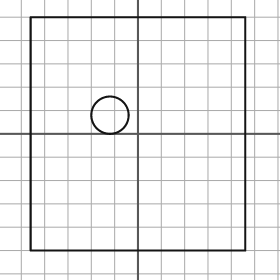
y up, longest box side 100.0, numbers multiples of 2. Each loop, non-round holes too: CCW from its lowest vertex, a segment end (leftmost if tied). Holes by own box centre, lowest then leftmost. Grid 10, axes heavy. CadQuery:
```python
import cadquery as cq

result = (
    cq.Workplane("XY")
    .moveTo(-46.0, -50.0)
    .lineTo(46.0, -50.0)
    .lineTo(46.0, 50.0)
    .lineTo(-46.0, 50.0)
    .close()
    .moveTo(-12.0, 8.0)
    .circle(8.0)
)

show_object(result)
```